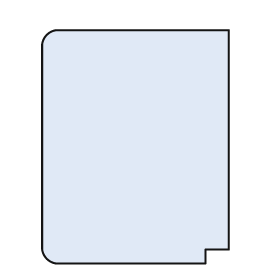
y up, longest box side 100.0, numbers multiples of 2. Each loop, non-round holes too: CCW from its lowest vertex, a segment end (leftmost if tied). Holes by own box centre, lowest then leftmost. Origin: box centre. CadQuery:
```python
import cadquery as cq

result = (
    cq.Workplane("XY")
    .moveTo(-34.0, -50.0)
    .lineTo(30.0, -50.0)
    .lineTo(30.0, -44.0)
    .lineTo(40.0, -44.0)
    .lineTo(40.0, 50.0)
    .lineTo(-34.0, 50.0)
    .threePointArc((-38.0, 48.0), (-40.0, 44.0))
    .lineTo(-40.0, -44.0)
    .threePointArc((-38.0, -48.0), (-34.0, -50.0))
    .close()
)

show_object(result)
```